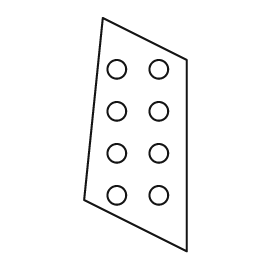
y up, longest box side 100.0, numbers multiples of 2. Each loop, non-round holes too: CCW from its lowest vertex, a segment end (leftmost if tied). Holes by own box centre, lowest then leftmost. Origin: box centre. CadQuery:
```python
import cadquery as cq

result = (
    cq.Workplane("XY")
    .moveTo(22.0, -50.0)
    .lineTo(22.0, 32.0)
    .lineTo(-14.0, 50.0)
    .lineTo(-22.0, -28.0)
    .close()
    .moveTo(-8.0, -26.0)
    .circle(4.0)
    .moveTo(10.0, -26.0)
    .circle(4.0)
    .moveTo(-8.0, -8.0)
    .circle(4.0)
    .moveTo(10.0, -8.0)
    .circle(4.0)
    .moveTo(-8.0, 10.0)
    .circle(4.0)
    .moveTo(10.0, 10.0)
    .circle(4.0)
    .moveTo(-8.0, 28.0)
    .circle(4.0)
    .moveTo(10.0, 28.0)
    .circle(4.0)
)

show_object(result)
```